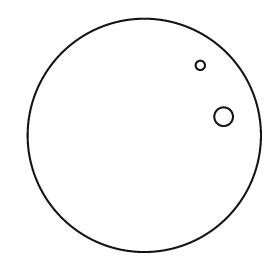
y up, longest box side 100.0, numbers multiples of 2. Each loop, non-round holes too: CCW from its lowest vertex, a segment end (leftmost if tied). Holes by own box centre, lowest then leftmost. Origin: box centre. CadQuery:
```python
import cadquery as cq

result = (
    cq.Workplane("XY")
    .moveTo(0.0, 0.0)
    .circle(50.0)
    .moveTo(34.0, 8.0)
    .circle(4.0)
    .moveTo(24.0, 30.0)
    .circle(2.0)
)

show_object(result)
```